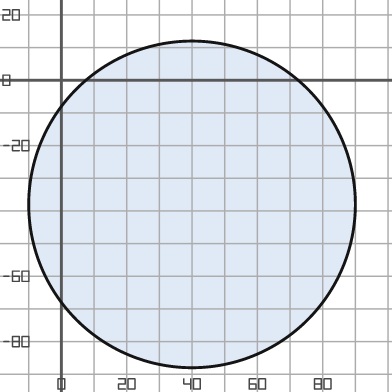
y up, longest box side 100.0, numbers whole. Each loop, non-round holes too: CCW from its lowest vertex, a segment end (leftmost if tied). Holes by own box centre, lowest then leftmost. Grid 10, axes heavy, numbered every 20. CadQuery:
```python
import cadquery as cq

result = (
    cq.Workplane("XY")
    .moveTo(40.0, -38.0)
    .circle(50.0)
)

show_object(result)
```